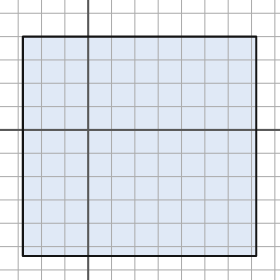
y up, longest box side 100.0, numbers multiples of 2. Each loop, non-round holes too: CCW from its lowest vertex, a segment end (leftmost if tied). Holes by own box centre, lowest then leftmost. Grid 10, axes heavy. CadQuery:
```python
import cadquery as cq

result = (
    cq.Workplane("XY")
    .moveTo(-28.0, -54.0)
    .lineTo(72.0, -54.0)
    .lineTo(72.0, 40.0)
    .lineTo(-28.0, 40.0)
    .close()
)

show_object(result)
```